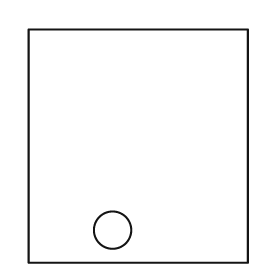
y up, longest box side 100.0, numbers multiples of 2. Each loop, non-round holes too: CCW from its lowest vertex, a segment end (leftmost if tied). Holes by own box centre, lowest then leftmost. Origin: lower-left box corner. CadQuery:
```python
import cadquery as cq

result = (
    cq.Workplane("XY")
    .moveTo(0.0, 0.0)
    .lineTo(94.0, 0.0)
    .lineTo(94.0, 100.0)
    .lineTo(0.0, 100.0)
    .close()
    .moveTo(36.0, 14.0)
    .circle(8.0)
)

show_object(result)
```